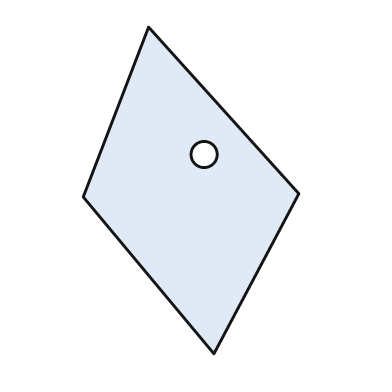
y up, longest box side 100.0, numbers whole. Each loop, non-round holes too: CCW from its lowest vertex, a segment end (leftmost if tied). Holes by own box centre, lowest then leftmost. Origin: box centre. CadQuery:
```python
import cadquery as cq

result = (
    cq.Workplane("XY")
    .moveTo(7.0, -50.0)
    .lineTo(33.0, -1.0)
    .lineTo(-13.0, 50.0)
    .lineTo(-33.0, -2.0)
    .close()
    .moveTo(4.0, 11.0)
    .circle(4.0)
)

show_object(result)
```